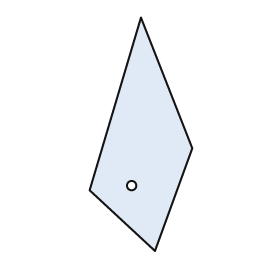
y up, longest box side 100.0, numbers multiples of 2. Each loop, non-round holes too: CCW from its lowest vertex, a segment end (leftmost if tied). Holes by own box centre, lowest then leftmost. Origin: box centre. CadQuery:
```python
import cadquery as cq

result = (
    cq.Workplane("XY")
    .moveTo(6.0, -50.0)
    .lineTo(22.0, -6.0)
    .lineTo(0.0, 50.0)
    .lineTo(-22.0, -24.0)
    .close()
    .moveTo(-4.0, -22.0)
    .circle(2.0)
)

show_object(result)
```